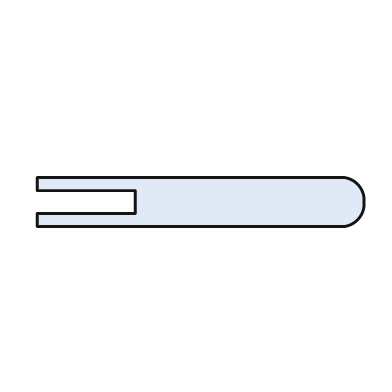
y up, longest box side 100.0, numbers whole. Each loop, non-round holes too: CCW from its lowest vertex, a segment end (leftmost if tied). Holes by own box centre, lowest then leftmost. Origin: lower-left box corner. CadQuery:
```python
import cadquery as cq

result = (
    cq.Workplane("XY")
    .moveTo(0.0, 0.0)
    .lineTo(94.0, 0.0)
    .threePointArc((98.0, 2.0), (100.0, 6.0))
    .lineTo(100.0, 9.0)
    .threePointArc((98.0, 13.0), (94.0, 15.0))
    .lineTo(0.0, 15.0)
    .lineTo(0.0, 11.0)
    .lineTo(30.0, 11.0)
    .lineTo(30.0, 4.0)
    .lineTo(0.0, 4.0)
    .close()
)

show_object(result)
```